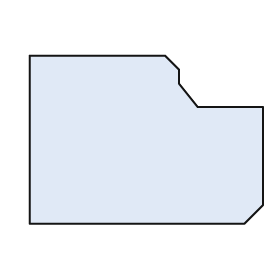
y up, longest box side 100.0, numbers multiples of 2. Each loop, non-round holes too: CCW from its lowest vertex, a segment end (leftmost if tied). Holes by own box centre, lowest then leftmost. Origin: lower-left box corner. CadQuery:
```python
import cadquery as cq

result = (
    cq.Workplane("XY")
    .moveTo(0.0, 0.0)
    .lineTo(92.0, 0.0)
    .lineTo(100.0, 8.0)
    .lineTo(100.0, 50.0)
    .lineTo(72.0, 50.0)
    .lineTo(64.0, 60.0)
    .lineTo(64.0, 66.0)
    .lineTo(58.0, 72.0)
    .lineTo(0.0, 72.0)
    .close()
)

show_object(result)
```